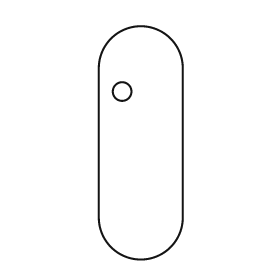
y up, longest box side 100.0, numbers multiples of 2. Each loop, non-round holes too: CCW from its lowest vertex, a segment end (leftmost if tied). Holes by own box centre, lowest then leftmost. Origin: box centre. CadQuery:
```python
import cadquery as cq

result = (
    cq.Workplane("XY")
    .moveTo(-18.0, -32.0)
    .threePointArc((0.0, -50.0), (18.0, -32.0))
    .lineTo(18.0, 32.0)
    .threePointArc((0.0, 50.0), (-18.0, 32.0))
    .close()
    .moveTo(-8.0, 22.0)
    .circle(4.0)
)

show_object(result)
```